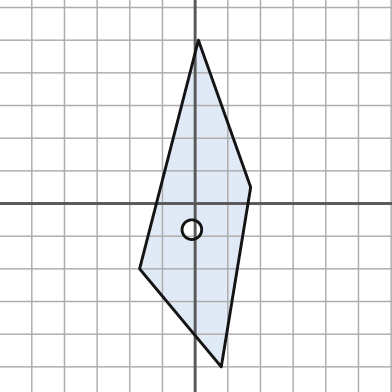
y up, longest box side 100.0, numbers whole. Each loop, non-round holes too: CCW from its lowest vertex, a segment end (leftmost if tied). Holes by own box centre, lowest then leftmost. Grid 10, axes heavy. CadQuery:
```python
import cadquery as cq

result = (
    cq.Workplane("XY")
    .moveTo(8.0, -50.0)
    .lineTo(17.0, 5.0)
    .lineTo(1.0, 50.0)
    .lineTo(-17.0, -20.0)
    .close()
    .moveTo(-1.0, -8.0)
    .circle(3.0)
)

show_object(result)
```